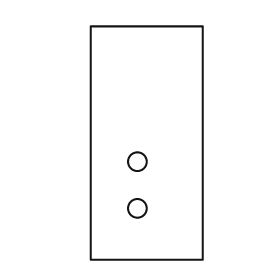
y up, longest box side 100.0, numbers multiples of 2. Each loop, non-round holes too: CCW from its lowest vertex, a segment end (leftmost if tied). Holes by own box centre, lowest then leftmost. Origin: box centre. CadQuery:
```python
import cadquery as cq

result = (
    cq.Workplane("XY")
    .moveTo(-24.0, -50.0)
    .lineTo(24.0, -50.0)
    .lineTo(24.0, 50.0)
    .lineTo(-24.0, 50.0)
    .close()
    .moveTo(-4.0, -28.0)
    .circle(4.0)
    .moveTo(-4.0, -8.0)
    .circle(4.0)
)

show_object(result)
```